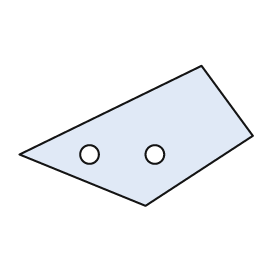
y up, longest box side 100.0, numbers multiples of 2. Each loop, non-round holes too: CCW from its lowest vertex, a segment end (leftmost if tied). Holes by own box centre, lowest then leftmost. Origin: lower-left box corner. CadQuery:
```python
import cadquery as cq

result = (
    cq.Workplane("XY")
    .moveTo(54.0, 0.0)
    .lineTo(100.0, 30.0)
    .lineTo(78.0, 60.0)
    .lineTo(0.0, 22.0)
    .close()
    .moveTo(30.0, 22.0)
    .circle(4.0)
    .moveTo(58.0, 22.0)
    .circle(4.0)
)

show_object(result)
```